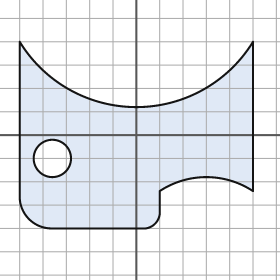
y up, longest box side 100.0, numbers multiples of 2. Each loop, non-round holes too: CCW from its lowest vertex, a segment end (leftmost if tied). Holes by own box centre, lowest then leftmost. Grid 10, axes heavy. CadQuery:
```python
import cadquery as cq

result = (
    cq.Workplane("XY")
    .moveTo(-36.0, -40.0)
    .lineTo(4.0, -40.0)
    .threePointArc((8.0, -38.0), (10.0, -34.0))
    .lineTo(10.0, -24.0)
    .threePointArc((30.0, -18.0), (50.0, -24.0))
    .lineTo(50.0, 40.0)
    .threePointArc((0.0, 12.0), (-50.0, 40.0))
    .lineTo(-50.0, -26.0)
    .threePointArc((-46.0, -36.0), (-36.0, -40.0))
    .close()
    .moveTo(-36.0, -10.0)
    .circle(8.0)
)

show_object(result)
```